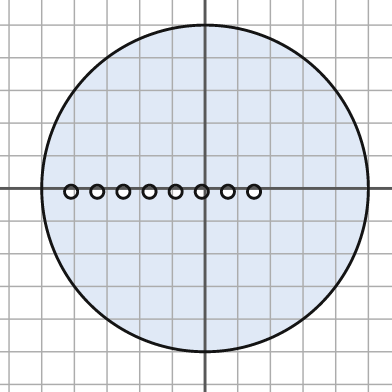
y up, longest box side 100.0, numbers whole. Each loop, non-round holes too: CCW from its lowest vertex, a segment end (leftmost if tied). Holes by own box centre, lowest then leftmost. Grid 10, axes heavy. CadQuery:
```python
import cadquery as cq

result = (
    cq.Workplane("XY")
    .moveTo(0.0, 0.0)
    .circle(50.0)
    .moveTo(-41.0, -1.0)
    .circle(2.0)
    .moveTo(-33.0, -1.0)
    .circle(2.0)
    .moveTo(-25.0, -1.0)
    .circle(2.0)
    .moveTo(-17.0, -1.0)
    .circle(2.0)
    .moveTo(-9.0, -1.0)
    .circle(2.0)
    .moveTo(-1.0, -1.0)
    .circle(2.0)
    .moveTo(7.0, -1.0)
    .circle(2.0)
    .moveTo(15.0, -1.0)
    .circle(2.0)
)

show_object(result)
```